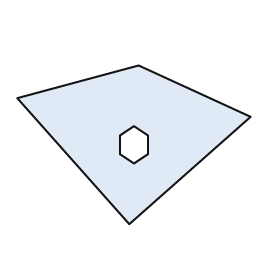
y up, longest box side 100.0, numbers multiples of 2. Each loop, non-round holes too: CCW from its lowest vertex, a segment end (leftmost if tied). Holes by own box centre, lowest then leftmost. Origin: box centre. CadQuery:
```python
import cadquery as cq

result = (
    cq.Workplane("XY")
    .moveTo(-2.0, -34.0)
    .lineTo(50.0, 12.0)
    .lineTo(2.0, 34.0)
    .lineTo(-50.0, 20.0)
    .close()
    .moveTo(0.0, -8.0)
    .lineTo(6.0, -4.0)
    .lineTo(6.0, 4.0)
    .lineTo(0.0, 8.0)
    .lineTo(-6.0, 4.0)
    .lineTo(-6.0, -4.0)
    .close()
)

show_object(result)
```